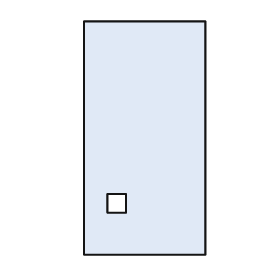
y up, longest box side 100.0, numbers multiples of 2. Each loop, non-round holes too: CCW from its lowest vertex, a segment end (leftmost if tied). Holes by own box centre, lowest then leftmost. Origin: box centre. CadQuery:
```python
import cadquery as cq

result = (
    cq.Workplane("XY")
    .moveTo(-26.0, -50.0)
    .lineTo(26.0, -50.0)
    .lineTo(26.0, 50.0)
    .lineTo(-26.0, 50.0)
    .close()
    .moveTo(-16.0, -32.0)
    .lineTo(-8.0, -32.0)
    .lineTo(-8.0, -24.0)
    .lineTo(-16.0, -24.0)
    .close()
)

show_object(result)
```